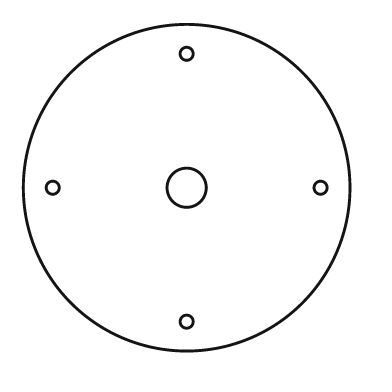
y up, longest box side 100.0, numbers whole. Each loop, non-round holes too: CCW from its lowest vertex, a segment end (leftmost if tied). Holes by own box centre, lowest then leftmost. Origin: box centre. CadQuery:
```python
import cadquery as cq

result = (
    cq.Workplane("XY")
    .moveTo(0.0, 0.0)
    .circle(50.0)
    .moveTo(0.0, -41.0)
    .circle(2.0)
    .moveTo(-41.0, 0.0)
    .circle(2.0)
    .moveTo(0.0, 0.0)
    .circle(6.0)
    .moveTo(41.0, 0.0)
    .circle(2.0)
    .moveTo(0.0, 41.0)
    .circle(2.0)
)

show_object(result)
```